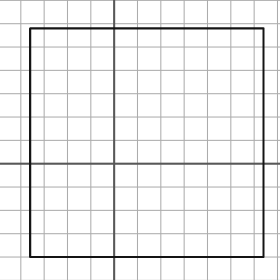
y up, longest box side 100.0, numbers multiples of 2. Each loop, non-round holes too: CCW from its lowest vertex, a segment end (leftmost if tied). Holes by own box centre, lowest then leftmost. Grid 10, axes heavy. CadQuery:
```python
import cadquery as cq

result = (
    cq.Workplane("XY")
    .moveTo(-36.0, -40.0)
    .lineTo(64.0, -40.0)
    .lineTo(64.0, 58.0)
    .lineTo(-36.0, 58.0)
    .close()
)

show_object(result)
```